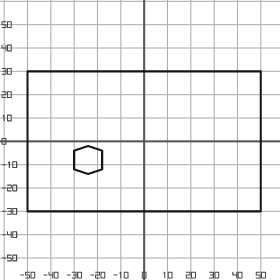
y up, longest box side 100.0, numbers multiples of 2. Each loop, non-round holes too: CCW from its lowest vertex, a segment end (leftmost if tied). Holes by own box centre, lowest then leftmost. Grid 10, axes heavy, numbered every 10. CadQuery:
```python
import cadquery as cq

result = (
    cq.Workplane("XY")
    .moveTo(-50.0, -30.0)
    .lineTo(50.0, -30.0)
    .lineTo(50.0, 30.0)
    .lineTo(-50.0, 30.0)
    .close()
    .moveTo(-24.0, -14.0)
    .lineTo(-18.0, -12.0)
    .lineTo(-18.0, -4.0)
    .lineTo(-24.0, -2.0)
    .lineTo(-30.0, -4.0)
    .lineTo(-30.0, -12.0)
    .close()
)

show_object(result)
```